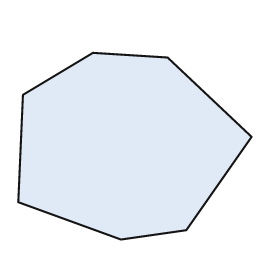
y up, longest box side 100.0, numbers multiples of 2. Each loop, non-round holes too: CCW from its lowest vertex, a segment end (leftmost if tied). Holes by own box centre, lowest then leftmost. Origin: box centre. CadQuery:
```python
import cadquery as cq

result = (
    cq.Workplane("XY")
    .moveTo(-6.0, -40.0)
    .lineTo(22.0, -36.0)
    .lineTo(50.0, 4.0)
    .lineTo(14.0, 38.0)
    .lineTo(-18.0, 40.0)
    .lineTo(-48.0, 22.0)
    .lineTo(-50.0, -24.0)
    .close()
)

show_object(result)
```